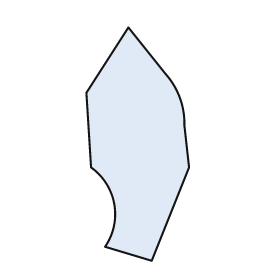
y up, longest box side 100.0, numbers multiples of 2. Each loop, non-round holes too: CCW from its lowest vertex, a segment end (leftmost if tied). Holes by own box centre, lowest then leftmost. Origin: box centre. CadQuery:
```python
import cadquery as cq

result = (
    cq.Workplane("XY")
    .moveTo(6.0, -50.0)
    .lineTo(22.0, -10.0)
    .lineTo(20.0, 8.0)
    .threePointArc((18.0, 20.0), (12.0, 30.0))
    .lineTo(-4.0, 50.0)
    .lineTo(-22.0, 22.0)
    .lineTo(-20.0, -10.0)
    .threePointArc((-10.0, -26.0), (-14.0, -44.0))
    .close()
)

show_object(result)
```